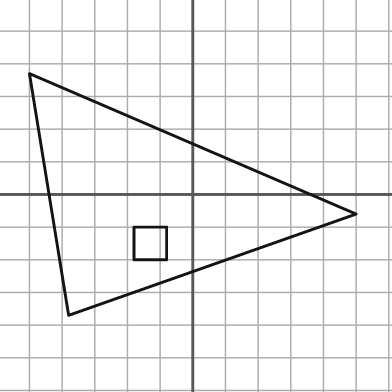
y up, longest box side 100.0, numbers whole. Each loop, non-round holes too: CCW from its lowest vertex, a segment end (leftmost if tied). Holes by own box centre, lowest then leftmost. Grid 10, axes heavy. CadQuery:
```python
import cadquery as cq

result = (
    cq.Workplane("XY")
    .moveTo(-38.0, -37.0)
    .lineTo(50.0, -6.0)
    .lineTo(-50.0, 37.0)
    .close()
    .moveTo(-18.0, -20.0)
    .lineTo(-8.0, -20.0)
    .lineTo(-8.0, -10.0)
    .lineTo(-18.0, -10.0)
    .close()
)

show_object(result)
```